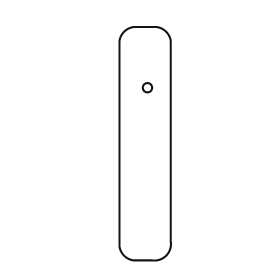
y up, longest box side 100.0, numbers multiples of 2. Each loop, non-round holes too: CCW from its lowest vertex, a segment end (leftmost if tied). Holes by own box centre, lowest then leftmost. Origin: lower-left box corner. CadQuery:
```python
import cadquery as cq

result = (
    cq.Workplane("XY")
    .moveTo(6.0, 0.0)
    .lineTo(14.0, 0.0)
    .threePointArc((20.0, 2.0), (22.0, 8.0))
    .lineTo(22.0, 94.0)
    .threePointArc((20.0, 98.0), (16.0, 100.0))
    .lineTo(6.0, 100.0)
    .threePointArc((2.0, 98.0), (0.0, 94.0))
    .lineTo(0.0, 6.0)
    .threePointArc((2.0, 2.0), (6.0, 0.0))
    .close()
    .moveTo(12.0, 74.0)
    .circle(2.0)
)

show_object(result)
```